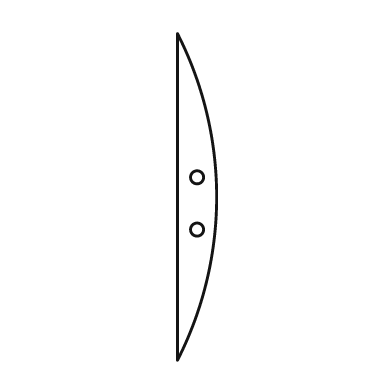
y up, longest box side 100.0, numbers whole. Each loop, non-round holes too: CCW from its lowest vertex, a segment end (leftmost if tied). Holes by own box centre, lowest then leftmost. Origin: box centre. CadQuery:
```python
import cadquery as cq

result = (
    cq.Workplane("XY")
    .moveTo(-6.0, -50.0)
    .threePointArc((6.0, 0.0), (-6.0, 50.0))
    .close()
    .moveTo(0.0, -10.0)
    .circle(2.0)
    .moveTo(0.0, 6.0)
    .circle(2.0)
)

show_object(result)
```